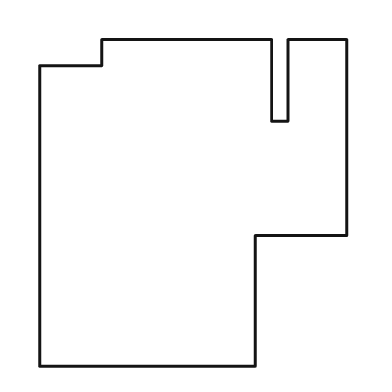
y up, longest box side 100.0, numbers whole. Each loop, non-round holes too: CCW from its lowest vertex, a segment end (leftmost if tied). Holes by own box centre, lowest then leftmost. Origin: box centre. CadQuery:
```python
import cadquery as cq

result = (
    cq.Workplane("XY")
    .moveTo(-47.0, -50.0)
    .lineTo(19.0, -50.0)
    .lineTo(19.0, -10.0)
    .lineTo(47.0, -10.0)
    .lineTo(47.0, 50.0)
    .lineTo(29.0, 50.0)
    .lineTo(29.0, 25.0)
    .lineTo(24.0, 25.0)
    .lineTo(24.0, 50.0)
    .lineTo(-28.0, 50.0)
    .lineTo(-28.0, 42.0)
    .lineTo(-47.0, 42.0)
    .close()
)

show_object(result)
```